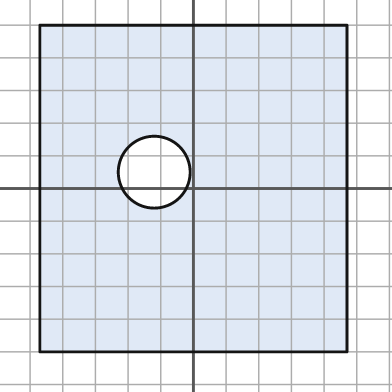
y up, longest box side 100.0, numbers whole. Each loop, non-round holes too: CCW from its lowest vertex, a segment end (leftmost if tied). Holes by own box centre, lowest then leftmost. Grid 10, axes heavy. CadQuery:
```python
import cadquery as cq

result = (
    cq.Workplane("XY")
    .moveTo(-47.0, -50.0)
    .lineTo(47.0, -50.0)
    .lineTo(47.0, 50.0)
    .lineTo(-47.0, 50.0)
    .close()
    .moveTo(-12.0, 5.0)
    .circle(11.0)
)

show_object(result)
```